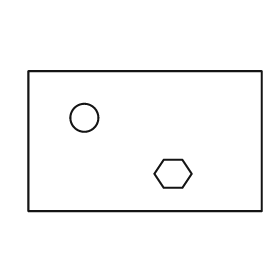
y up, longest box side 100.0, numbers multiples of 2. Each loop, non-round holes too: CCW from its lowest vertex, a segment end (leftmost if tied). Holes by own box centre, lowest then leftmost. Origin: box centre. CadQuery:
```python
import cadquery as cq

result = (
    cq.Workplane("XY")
    .moveTo(-50.0, -30.0)
    .lineTo(50.0, -30.0)
    .lineTo(50.0, 30.0)
    .lineTo(-50.0, 30.0)
    .close()
    .moveTo(8.0, -20.0)
    .lineTo(16.0, -20.0)
    .lineTo(20.0, -14.0)
    .lineTo(16.0, -8.0)
    .lineTo(8.0, -8.0)
    .lineTo(4.0, -14.0)
    .close()
    .moveTo(-26.0, 10.0)
    .circle(6.0)
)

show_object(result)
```